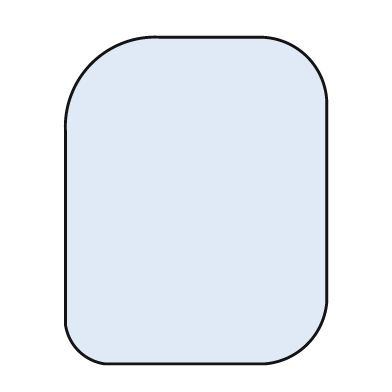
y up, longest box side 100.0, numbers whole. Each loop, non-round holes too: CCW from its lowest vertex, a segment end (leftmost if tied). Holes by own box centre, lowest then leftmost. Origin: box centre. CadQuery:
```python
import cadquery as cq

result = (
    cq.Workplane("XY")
    .moveTo(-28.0, -50.0)
    .lineTo(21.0, -50.0)
    .threePointArc((34.0, -44.0), (40.0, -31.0))
    .lineTo(40.0, 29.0)
    .threePointArc((34.0, 44.0), (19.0, 50.0))
    .lineTo(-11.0, 50.0)
    .threePointArc((-32.0, 42.0), (-40.0, 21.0))
    .lineTo(-40.0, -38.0)
    .threePointArc((-36.0, -46.0), (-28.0, -50.0))
    .close()
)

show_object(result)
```